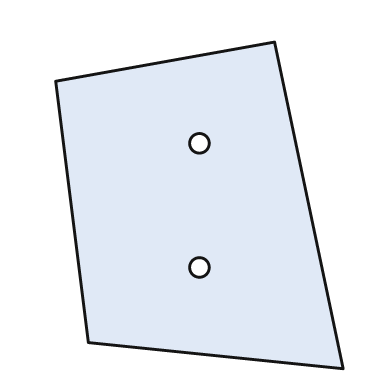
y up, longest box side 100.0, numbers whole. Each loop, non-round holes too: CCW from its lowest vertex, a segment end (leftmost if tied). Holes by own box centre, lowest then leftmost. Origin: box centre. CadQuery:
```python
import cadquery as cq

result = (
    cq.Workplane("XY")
    .moveTo(44.0, -50.0)
    .lineTo(23.0, 50.0)
    .lineTo(-44.0, 38.0)
    .lineTo(-34.0, -42.0)
    .close()
    .moveTo(0.0, -19.0)
    .circle(3.0)
    .moveTo(0.0, 19.0)
    .circle(3.0)
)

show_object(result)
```